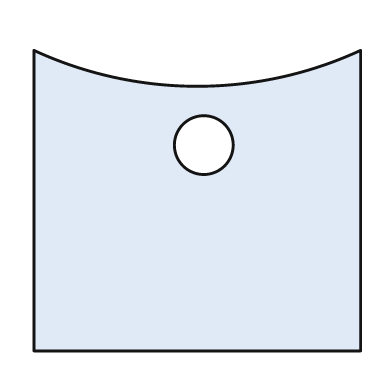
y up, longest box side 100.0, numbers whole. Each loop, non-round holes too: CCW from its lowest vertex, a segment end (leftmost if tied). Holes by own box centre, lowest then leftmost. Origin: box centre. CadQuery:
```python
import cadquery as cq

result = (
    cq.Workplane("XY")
    .moveTo(-50.0, -46.0)
    .lineTo(50.0, -46.0)
    .lineTo(50.0, 46.0)
    .threePointArc((0.0, 35.0), (-50.0, 46.0))
    .close()
    .moveTo(2.0, 17.0)
    .circle(9.0)
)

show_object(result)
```